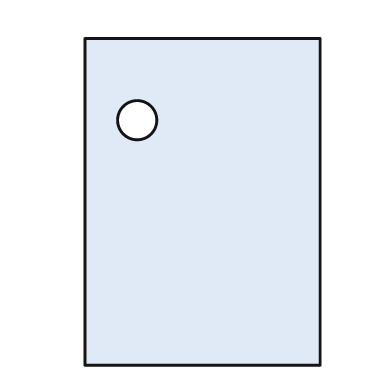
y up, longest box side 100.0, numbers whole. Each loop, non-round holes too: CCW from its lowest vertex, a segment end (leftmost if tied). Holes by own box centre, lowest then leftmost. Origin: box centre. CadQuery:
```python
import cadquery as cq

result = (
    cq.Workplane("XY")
    .moveTo(-36.0, -50.0)
    .lineTo(36.0, -50.0)
    .lineTo(36.0, 50.0)
    .lineTo(-36.0, 50.0)
    .close()
    .moveTo(-20.0, 25.0)
    .circle(6.0)
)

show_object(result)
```